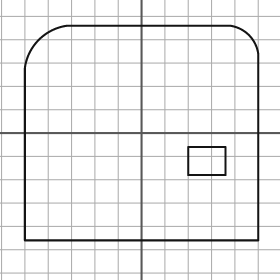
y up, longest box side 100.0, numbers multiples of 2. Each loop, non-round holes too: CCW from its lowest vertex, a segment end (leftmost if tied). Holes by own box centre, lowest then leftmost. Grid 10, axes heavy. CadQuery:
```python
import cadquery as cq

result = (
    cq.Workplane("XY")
    .moveTo(-50.0, -46.0)
    .lineTo(50.0, -46.0)
    .lineTo(50.0, 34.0)
    .threePointArc((46.0, 42.0), (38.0, 46.0))
    .lineTo(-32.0, 46.0)
    .threePointArc((-44.0, 40.0), (-50.0, 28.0))
    .close()
    .moveTo(20.0, -18.0)
    .lineTo(36.0, -18.0)
    .lineTo(36.0, -6.0)
    .lineTo(20.0, -6.0)
    .close()
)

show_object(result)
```